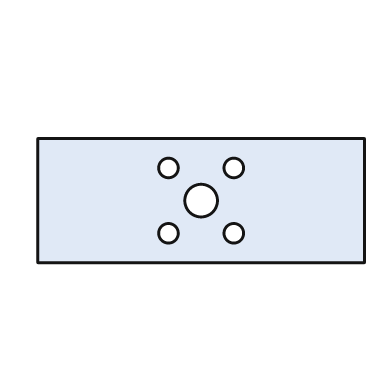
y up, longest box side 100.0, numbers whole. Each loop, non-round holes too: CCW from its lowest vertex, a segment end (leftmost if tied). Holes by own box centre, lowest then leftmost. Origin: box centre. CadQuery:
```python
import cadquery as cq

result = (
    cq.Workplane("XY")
    .moveTo(-50.0, -19.0)
    .lineTo(50.0, -19.0)
    .lineTo(50.0, 19.0)
    .lineTo(-50.0, 19.0)
    .close()
    .moveTo(-10.0, -10.0)
    .circle(3.0)
    .moveTo(10.0, -10.0)
    .circle(3.0)
    .moveTo(0.0, 0.0)
    .circle(5.0)
    .moveTo(-10.0, 10.0)
    .circle(3.0)
    .moveTo(10.0, 10.0)
    .circle(3.0)
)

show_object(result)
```